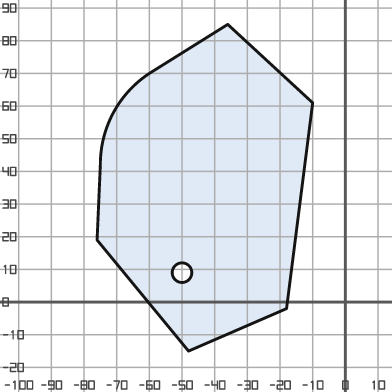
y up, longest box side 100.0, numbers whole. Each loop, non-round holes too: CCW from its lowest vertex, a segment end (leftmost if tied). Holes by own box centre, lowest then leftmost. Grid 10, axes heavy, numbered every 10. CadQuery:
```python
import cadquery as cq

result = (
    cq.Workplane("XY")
    .moveTo(-48.0, -15.0)
    .lineTo(-18.0, -2.0)
    .lineTo(-10.0, 61.0)
    .lineTo(-36.0, 85.0)
    .lineTo(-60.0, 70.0)
    .threePointArc((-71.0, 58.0), (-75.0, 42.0))
    .lineTo(-76.0, 19.0)
    .close()
    .moveTo(-50.0, 9.0)
    .circle(3.0)
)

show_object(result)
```